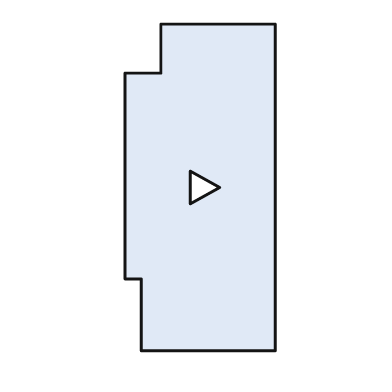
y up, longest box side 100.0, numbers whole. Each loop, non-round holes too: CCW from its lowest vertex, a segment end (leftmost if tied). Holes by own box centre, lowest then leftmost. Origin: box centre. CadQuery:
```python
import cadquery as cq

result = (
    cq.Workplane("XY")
    .moveTo(-18.0, -50.0)
    .lineTo(23.0, -50.0)
    .lineTo(23.0, 50.0)
    .lineTo(-12.0, 50.0)
    .lineTo(-12.0, 35.0)
    .lineTo(-23.0, 35.0)
    .lineTo(-23.0, -28.0)
    .lineTo(-18.0, -28.0)
    .close()
    .moveTo(-3.0, -5.0)
    .lineTo(6.0, 0.0)
    .lineTo(-3.0, 5.0)
    .close()
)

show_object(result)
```